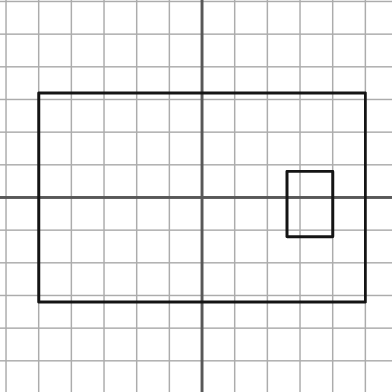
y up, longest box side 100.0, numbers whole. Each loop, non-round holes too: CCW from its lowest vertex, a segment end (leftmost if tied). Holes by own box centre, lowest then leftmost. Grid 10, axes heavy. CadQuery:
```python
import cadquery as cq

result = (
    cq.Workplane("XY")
    .moveTo(-50.0, -32.0)
    .lineTo(50.0, -32.0)
    .lineTo(50.0, 32.0)
    .lineTo(-50.0, 32.0)
    .close()
    .moveTo(26.0, -12.0)
    .lineTo(40.0, -12.0)
    .lineTo(40.0, 8.0)
    .lineTo(26.0, 8.0)
    .close()
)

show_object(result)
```